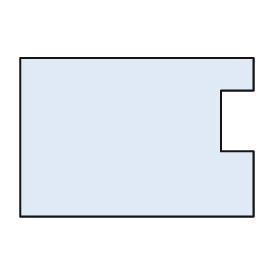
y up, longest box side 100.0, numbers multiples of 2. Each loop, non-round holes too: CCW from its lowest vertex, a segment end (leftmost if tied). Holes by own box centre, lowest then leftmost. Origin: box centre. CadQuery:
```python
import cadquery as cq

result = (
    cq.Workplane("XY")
    .moveTo(-50.0, -34.0)
    .lineTo(50.0, -34.0)
    .lineTo(50.0, -6.0)
    .lineTo(36.0, -6.0)
    .lineTo(36.0, 20.0)
    .lineTo(50.0, 20.0)
    .lineTo(50.0, 34.0)
    .lineTo(-50.0, 34.0)
    .close()
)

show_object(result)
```